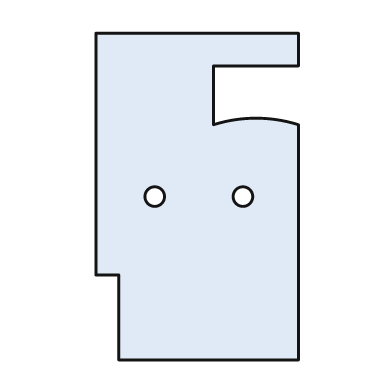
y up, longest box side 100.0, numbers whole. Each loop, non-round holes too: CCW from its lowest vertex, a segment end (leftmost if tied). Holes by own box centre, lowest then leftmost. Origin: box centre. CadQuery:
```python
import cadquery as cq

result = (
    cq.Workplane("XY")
    .moveTo(-24.0, -50.0)
    .lineTo(31.0, -50.0)
    .lineTo(31.0, 22.0)
    .threePointArc((18.0, 24.0), (5.0, 22.0))
    .lineTo(5.0, 40.0)
    .lineTo(31.0, 40.0)
    .lineTo(31.0, 50.0)
    .lineTo(-31.0, 50.0)
    .lineTo(-31.0, -24.0)
    .lineTo(-24.0, -24.0)
    .close()
    .moveTo(-13.0, 0.0)
    .circle(3.0)
    .moveTo(14.0, 0.0)
    .circle(3.0)
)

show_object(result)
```